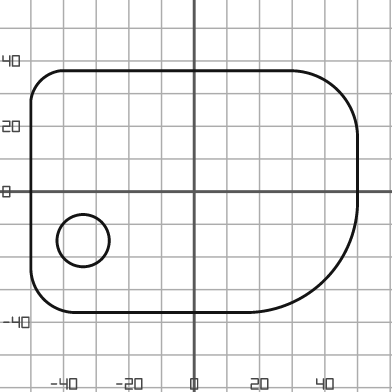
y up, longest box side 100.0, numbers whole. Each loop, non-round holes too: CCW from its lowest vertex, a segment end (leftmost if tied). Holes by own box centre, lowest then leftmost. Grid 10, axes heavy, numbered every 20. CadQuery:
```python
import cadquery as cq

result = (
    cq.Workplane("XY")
    .moveTo(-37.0, -37.0)
    .lineTo(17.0, -37.0)
    .threePointArc((40.0, -27.0), (50.0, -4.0))
    .lineTo(50.0, 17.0)
    .threePointArc((44.0, 31.0), (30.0, 37.0))
    .lineTo(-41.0, 37.0)
    .threePointArc((-47.0, 34.0), (-50.0, 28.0))
    .lineTo(-50.0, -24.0)
    .threePointArc((-46.0, -33.0), (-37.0, -37.0))
    .close()
    .moveTo(-34.0, -15.0)
    .circle(8.0)
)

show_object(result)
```